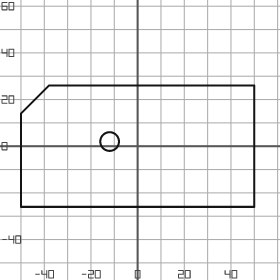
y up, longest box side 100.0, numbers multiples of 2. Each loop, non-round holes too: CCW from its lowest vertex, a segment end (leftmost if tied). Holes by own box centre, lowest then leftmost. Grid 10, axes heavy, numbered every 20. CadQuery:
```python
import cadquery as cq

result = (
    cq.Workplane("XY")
    .moveTo(-50.0, -26.0)
    .lineTo(50.0, -26.0)
    .lineTo(50.0, 26.0)
    .lineTo(-38.0, 26.0)
    .lineTo(-50.0, 14.0)
    .close()
    .moveTo(-12.0, 2.0)
    .circle(4.0)
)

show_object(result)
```